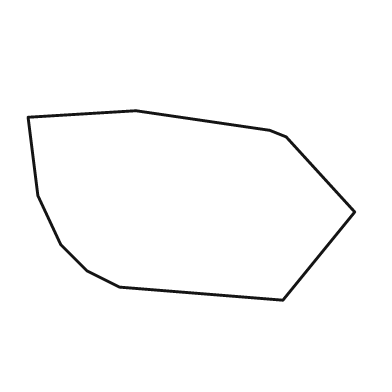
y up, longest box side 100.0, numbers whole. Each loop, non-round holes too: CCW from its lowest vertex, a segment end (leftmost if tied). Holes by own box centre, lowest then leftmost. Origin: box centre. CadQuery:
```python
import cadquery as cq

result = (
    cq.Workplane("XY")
    .moveTo(28.0, -29.0)
    .lineTo(50.0, -2.0)
    .lineTo(29.0, 21.0)
    .lineTo(24.0, 23.0)
    .lineTo(-17.0, 29.0)
    .lineTo(-50.0, 27.0)
    .lineTo(-47.0, 3.0)
    .lineTo(-40.0, -12.0)
    .lineTo(-32.0, -20.0)
    .lineTo(-22.0, -25.0)
    .close()
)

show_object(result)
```